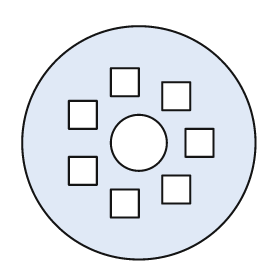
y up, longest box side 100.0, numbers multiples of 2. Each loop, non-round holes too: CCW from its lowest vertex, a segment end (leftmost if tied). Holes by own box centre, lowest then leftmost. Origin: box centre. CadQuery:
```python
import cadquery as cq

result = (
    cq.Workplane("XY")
    .moveTo(0.0, 0.0)
    .circle(50.0)
    .moveTo(-12.0, -32.0)
    .lineTo(0.0, -32.0)
    .lineTo(0.0, -20.0)
    .lineTo(-12.0, -20.0)
    .close()
    .moveTo(10.0, -26.0)
    .lineTo(22.0, -26.0)
    .lineTo(22.0, -14.0)
    .lineTo(10.0, -14.0)
    .close()
    .moveTo(-30.0, -18.0)
    .lineTo(-18.0, -18.0)
    .lineTo(-18.0, -6.0)
    .lineTo(-30.0, -6.0)
    .close()
    .moveTo(0.0, 0.0)
    .circle(12.0)
    .moveTo(20.0, -6.0)
    .lineTo(32.0, -6.0)
    .lineTo(32.0, 6.0)
    .lineTo(20.0, 6.0)
    .close()
    .moveTo(-30.0, 6.0)
    .lineTo(-18.0, 6.0)
    .lineTo(-18.0, 18.0)
    .lineTo(-30.0, 18.0)
    .close()
    .moveTo(10.0, 14.0)
    .lineTo(22.0, 14.0)
    .lineTo(22.0, 26.0)
    .lineTo(10.0, 26.0)
    .close()
    .moveTo(-12.0, 20.0)
    .lineTo(0.0, 20.0)
    .lineTo(0.0, 32.0)
    .lineTo(-12.0, 32.0)
    .close()
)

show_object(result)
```